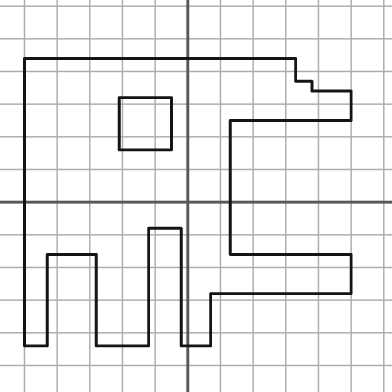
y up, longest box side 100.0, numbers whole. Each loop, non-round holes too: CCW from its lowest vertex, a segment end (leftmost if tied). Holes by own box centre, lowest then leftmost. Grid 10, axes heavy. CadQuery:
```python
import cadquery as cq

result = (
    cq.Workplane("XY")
    .moveTo(-50.0, -44.0)
    .lineTo(-43.0, -44.0)
    .lineTo(-43.0, -16.0)
    .lineTo(-28.0, -16.0)
    .lineTo(-28.0, -44.0)
    .lineTo(-12.0, -44.0)
    .lineTo(-12.0, -8.0)
    .lineTo(-2.0, -8.0)
    .lineTo(-2.0, -44.0)
    .lineTo(7.0, -44.0)
    .lineTo(7.0, -28.0)
    .lineTo(50.0, -28.0)
    .lineTo(50.0, -16.0)
    .lineTo(13.0, -16.0)
    .lineTo(13.0, 25.0)
    .lineTo(50.0, 25.0)
    .lineTo(50.0, 34.0)
    .lineTo(38.0, 34.0)
    .lineTo(38.0, 37.0)
    .lineTo(33.0, 37.0)
    .lineTo(33.0, 44.0)
    .lineTo(-50.0, 44.0)
    .close()
    .moveTo(-21.0, 16.0)
    .lineTo(-5.0, 16.0)
    .lineTo(-5.0, 32.0)
    .lineTo(-21.0, 32.0)
    .close()
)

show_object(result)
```